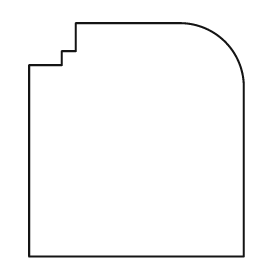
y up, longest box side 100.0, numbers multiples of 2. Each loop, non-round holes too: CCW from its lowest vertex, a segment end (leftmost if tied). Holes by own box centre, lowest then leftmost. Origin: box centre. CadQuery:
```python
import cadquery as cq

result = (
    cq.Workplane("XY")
    .moveTo(-46.0, -50.0)
    .lineTo(46.0, -50.0)
    .lineTo(46.0, 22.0)
    .threePointArc((38.0, 42.0), (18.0, 50.0))
    .lineTo(-26.0, 50.0)
    .lineTo(-26.0, 38.0)
    .lineTo(-32.0, 38.0)
    .lineTo(-32.0, 32.0)
    .lineTo(-46.0, 32.0)
    .close()
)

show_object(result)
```